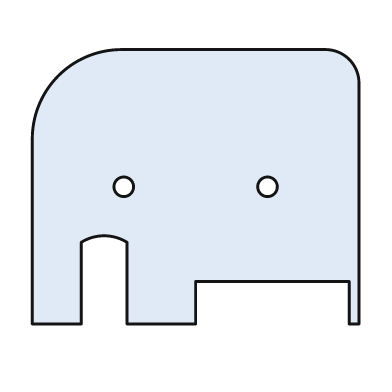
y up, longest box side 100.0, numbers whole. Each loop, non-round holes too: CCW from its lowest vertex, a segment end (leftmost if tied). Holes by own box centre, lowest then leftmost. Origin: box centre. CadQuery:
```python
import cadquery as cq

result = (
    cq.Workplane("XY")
    .moveTo(-50.0, -42.0)
    .lineTo(-35.0, -42.0)
    .lineTo(-35.0, -17.0)
    .threePointArc((-28.0, -15.0), (-21.0, -17.0))
    .lineTo(-21.0, -42.0)
    .lineTo(0.0, -42.0)
    .lineTo(0.0, -29.0)
    .lineTo(47.0, -29.0)
    .lineTo(47.0, -42.0)
    .lineTo(50.0, -42.0)
    .lineTo(50.0, 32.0)
    .threePointArc((47.0, 39.0), (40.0, 42.0))
    .lineTo(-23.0, 42.0)
    .threePointArc((-42.0, 34.0), (-50.0, 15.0))
    .close()
    .moveTo(-22.0, 0.0)
    .circle(3.0)
    .moveTo(22.0, 0.0)
    .circle(3.0)
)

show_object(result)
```